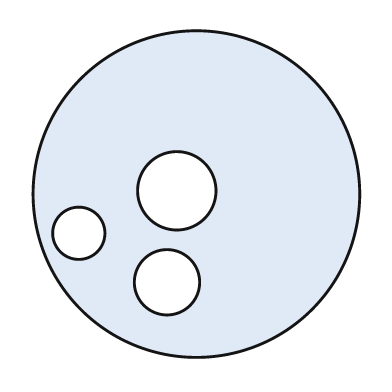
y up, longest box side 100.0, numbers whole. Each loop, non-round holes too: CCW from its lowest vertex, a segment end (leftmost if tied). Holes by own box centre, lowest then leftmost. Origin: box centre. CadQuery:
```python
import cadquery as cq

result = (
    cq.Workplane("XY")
    .moveTo(0.0, 0.0)
    .circle(50.0)
    .moveTo(-9.0, -27.0)
    .circle(10.0)
    .moveTo(-36.0, -12.0)
    .circle(8.0)
    .moveTo(-6.0, 1.0)
    .circle(12.0)
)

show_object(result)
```